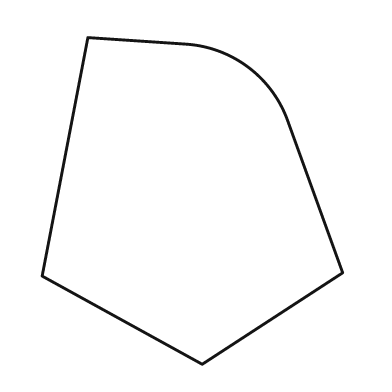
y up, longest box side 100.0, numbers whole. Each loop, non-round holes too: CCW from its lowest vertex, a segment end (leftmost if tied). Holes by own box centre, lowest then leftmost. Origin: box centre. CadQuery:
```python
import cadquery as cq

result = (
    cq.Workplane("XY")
    .moveTo(3.0, -50.0)
    .lineTo(46.0, -22.0)
    .lineTo(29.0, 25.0)
    .threePointArc((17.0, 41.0), (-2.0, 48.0))
    .lineTo(-32.0, 50.0)
    .lineTo(-46.0, -23.0)
    .close()
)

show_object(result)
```